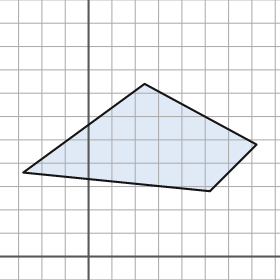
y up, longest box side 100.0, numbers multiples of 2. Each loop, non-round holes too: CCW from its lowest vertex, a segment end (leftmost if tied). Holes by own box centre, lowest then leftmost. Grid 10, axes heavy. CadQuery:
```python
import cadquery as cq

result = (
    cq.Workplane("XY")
    .moveTo(52.0, 28.0)
    .lineTo(72.0, 48.0)
    .lineTo(24.0, 74.0)
    .lineTo(-28.0, 36.0)
    .close()
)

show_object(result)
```